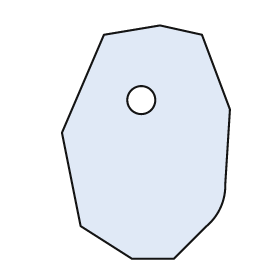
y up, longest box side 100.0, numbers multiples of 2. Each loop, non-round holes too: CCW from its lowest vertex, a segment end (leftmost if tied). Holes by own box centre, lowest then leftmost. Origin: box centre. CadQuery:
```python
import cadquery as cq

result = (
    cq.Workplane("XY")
    .moveTo(-6.0, -50.0)
    .lineTo(12.0, -50.0)
    .lineTo(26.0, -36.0)
    .threePointArc((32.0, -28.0), (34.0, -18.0))
    .lineTo(36.0, 14.0)
    .lineTo(24.0, 46.0)
    .lineTo(6.0, 50.0)
    .lineTo(-18.0, 46.0)
    .lineTo(-36.0, 4.0)
    .lineTo(-28.0, -36.0)
    .close()
    .moveTo(-2.0, 18.0)
    .circle(6.0)
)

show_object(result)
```